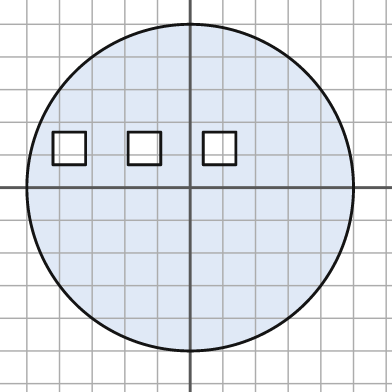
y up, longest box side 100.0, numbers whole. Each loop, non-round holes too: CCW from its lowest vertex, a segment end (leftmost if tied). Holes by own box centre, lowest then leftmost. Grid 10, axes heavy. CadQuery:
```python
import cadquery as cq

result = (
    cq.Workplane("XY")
    .moveTo(0.0, 0.0)
    .circle(50.0)
    .moveTo(-42.0, 7.0)
    .lineTo(-32.0, 7.0)
    .lineTo(-32.0, 17.0)
    .lineTo(-42.0, 17.0)
    .close()
    .moveTo(-19.0, 7.0)
    .lineTo(-9.0, 7.0)
    .lineTo(-9.0, 17.0)
    .lineTo(-19.0, 17.0)
    .close()
    .moveTo(4.0, 7.0)
    .lineTo(14.0, 7.0)
    .lineTo(14.0, 17.0)
    .lineTo(4.0, 17.0)
    .close()
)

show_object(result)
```